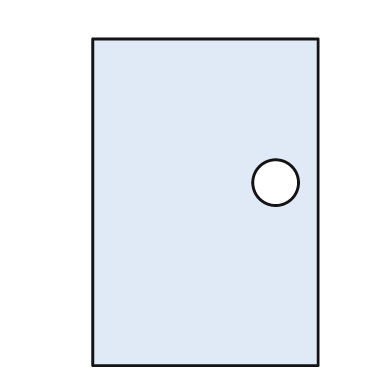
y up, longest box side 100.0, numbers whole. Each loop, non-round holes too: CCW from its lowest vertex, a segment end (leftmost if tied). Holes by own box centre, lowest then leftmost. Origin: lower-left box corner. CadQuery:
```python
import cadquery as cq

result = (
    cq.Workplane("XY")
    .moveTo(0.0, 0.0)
    .lineTo(69.0, 0.0)
    .lineTo(69.0, 100.0)
    .lineTo(0.0, 100.0)
    .close()
    .moveTo(56.0, 56.0)
    .circle(7.0)
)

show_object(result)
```